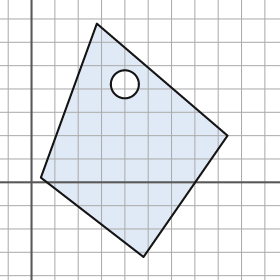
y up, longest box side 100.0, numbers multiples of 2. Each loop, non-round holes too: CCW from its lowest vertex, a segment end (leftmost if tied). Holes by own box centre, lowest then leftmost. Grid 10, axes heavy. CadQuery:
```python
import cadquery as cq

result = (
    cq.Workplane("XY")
    .moveTo(48.0, -32.0)
    .lineTo(84.0, 20.0)
    .lineTo(28.0, 68.0)
    .lineTo(4.0, 2.0)
    .close()
    .moveTo(40.0, 42.0)
    .circle(6.0)
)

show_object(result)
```